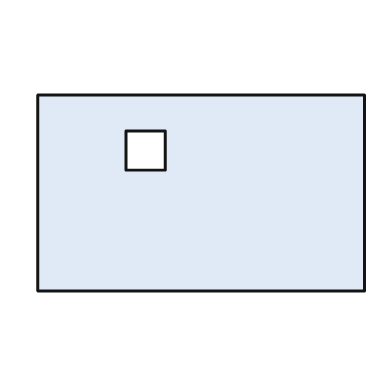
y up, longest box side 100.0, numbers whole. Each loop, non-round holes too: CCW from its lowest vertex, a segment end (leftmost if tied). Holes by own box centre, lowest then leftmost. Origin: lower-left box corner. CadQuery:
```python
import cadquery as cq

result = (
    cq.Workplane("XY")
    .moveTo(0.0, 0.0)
    .lineTo(100.0, 0.0)
    .lineTo(100.0, 60.0)
    .lineTo(0.0, 60.0)
    .close()
    .moveTo(27.0, 37.0)
    .lineTo(39.0, 37.0)
    .lineTo(39.0, 49.0)
    .lineTo(27.0, 49.0)
    .close()
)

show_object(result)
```